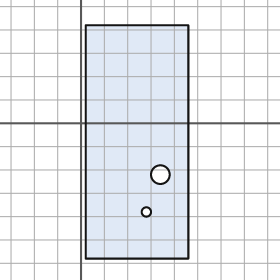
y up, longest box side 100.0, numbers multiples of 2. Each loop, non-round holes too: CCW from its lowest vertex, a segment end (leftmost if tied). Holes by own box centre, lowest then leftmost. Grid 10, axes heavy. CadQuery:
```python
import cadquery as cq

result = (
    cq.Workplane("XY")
    .moveTo(2.0, -58.0)
    .lineTo(46.0, -58.0)
    .lineTo(46.0, 42.0)
    .lineTo(2.0, 42.0)
    .close()
    .moveTo(28.0, -38.0)
    .circle(2.0)
    .moveTo(34.0, -22.0)
    .circle(4.0)
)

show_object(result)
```